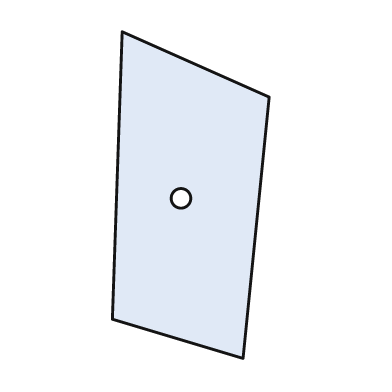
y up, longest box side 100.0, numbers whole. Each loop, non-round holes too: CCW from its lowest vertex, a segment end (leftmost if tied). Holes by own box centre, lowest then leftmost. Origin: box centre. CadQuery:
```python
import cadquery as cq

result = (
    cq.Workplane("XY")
    .moveTo(16.0, -50.0)
    .lineTo(24.0, 30.0)
    .lineTo(-21.0, 50.0)
    .lineTo(-24.0, -38.0)
    .close()
    .moveTo(-3.0, -1.0)
    .circle(3.0)
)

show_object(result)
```